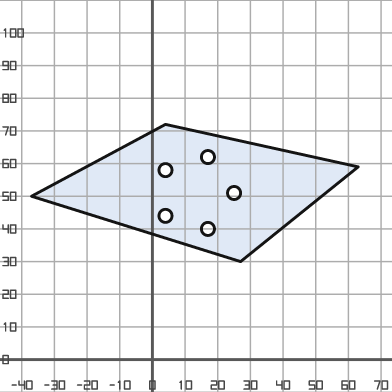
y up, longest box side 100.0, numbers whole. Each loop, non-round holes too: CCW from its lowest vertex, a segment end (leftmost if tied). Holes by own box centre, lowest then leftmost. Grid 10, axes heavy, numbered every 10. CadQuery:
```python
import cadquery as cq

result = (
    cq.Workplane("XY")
    .moveTo(27.0, 30.0)
    .lineTo(63.0, 59.0)
    .lineTo(4.0, 72.0)
    .lineTo(-37.0, 50.0)
    .close()
    .moveTo(17.0, 40.0)
    .circle(2.0)
    .moveTo(4.0, 44.0)
    .circle(2.0)
    .moveTo(25.0, 51.0)
    .circle(2.0)
    .moveTo(4.0, 58.0)
    .circle(2.0)
    .moveTo(17.0, 62.0)
    .circle(2.0)
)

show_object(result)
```